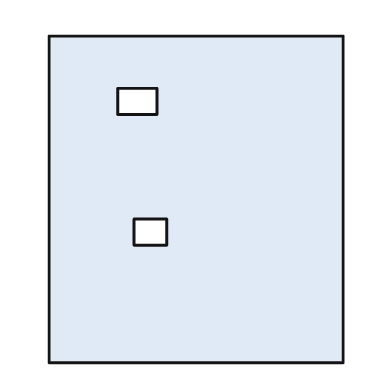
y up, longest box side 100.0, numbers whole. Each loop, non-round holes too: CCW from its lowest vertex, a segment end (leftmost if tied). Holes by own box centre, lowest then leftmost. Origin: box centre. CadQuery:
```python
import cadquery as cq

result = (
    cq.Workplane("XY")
    .moveTo(-45.0, -50.0)
    .lineTo(45.0, -50.0)
    .lineTo(45.0, 50.0)
    .lineTo(-45.0, 50.0)
    .close()
    .moveTo(-19.0, -14.0)
    .lineTo(-9.0, -14.0)
    .lineTo(-9.0, -6.0)
    .lineTo(-19.0, -6.0)
    .close()
    .moveTo(-24.0, 26.0)
    .lineTo(-12.0, 26.0)
    .lineTo(-12.0, 34.0)
    .lineTo(-24.0, 34.0)
    .close()
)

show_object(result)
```